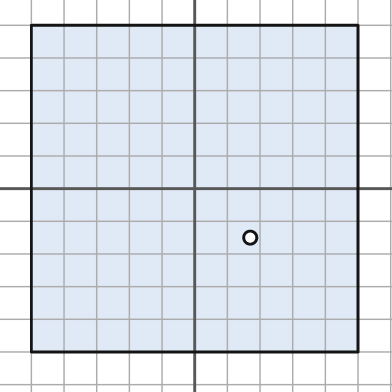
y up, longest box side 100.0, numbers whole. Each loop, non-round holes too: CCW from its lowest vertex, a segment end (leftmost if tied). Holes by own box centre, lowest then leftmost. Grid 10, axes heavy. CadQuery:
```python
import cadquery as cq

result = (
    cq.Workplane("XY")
    .moveTo(-50.0, -50.0)
    .lineTo(50.0, -50.0)
    .lineTo(50.0, 50.0)
    .lineTo(-50.0, 50.0)
    .close()
    .moveTo(17.0, -15.0)
    .circle(2.0)
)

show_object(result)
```